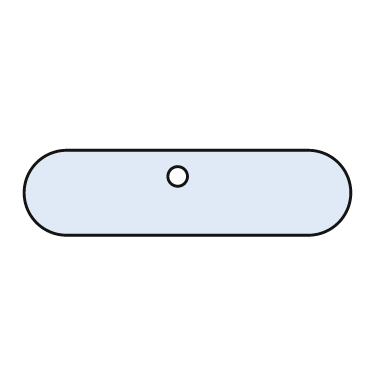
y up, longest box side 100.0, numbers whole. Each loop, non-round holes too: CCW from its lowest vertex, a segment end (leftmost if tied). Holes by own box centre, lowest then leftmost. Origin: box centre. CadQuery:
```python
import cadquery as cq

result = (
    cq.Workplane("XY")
    .moveTo(-37.0, -13.0)
    .lineTo(37.0, -13.0)
    .threePointArc((50.0, 0.0), (37.0, 13.0))
    .lineTo(-37.0, 13.0)
    .threePointArc((-50.0, 0.0), (-37.0, -13.0))
    .close()
    .moveTo(-3.0, 5.0)
    .circle(3.0)
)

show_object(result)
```